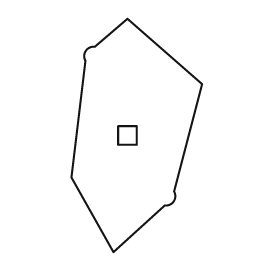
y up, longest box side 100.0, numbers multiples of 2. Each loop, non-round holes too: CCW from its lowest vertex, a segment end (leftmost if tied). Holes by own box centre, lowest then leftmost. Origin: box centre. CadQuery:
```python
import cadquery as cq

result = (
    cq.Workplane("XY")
    .moveTo(-10.0, -50.0)
    .lineTo(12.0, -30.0)
    .threePointArc((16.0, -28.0), (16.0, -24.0))
    .lineTo(28.0, 22.0)
    .lineTo(-4.0, 50.0)
    .lineTo(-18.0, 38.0)
    .threePointArc((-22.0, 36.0), (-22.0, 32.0))
    .lineTo(-28.0, -18.0)
    .close()
    .moveTo(-8.0, -4.0)
    .lineTo(0.0, -4.0)
    .lineTo(0.0, 4.0)
    .lineTo(-8.0, 4.0)
    .close()
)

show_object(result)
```